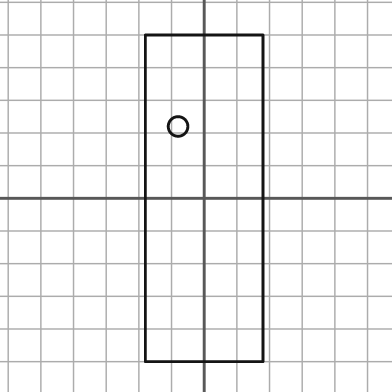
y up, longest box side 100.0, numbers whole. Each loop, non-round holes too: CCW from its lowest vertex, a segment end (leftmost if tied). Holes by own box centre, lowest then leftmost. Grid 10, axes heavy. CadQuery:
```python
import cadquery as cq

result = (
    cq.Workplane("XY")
    .moveTo(-18.0, -50.0)
    .lineTo(18.0, -50.0)
    .lineTo(18.0, 50.0)
    .lineTo(-18.0, 50.0)
    .close()
    .moveTo(-8.0, 22.0)
    .circle(3.0)
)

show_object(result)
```